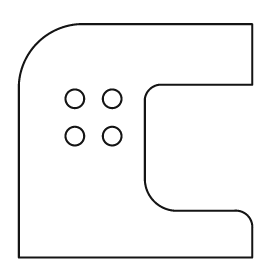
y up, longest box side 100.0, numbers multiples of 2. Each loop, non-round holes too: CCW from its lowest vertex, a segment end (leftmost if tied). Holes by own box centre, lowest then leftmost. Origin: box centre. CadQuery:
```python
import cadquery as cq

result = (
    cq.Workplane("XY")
    .moveTo(-50.0, -50.0)
    .lineTo(50.0, -50.0)
    .lineTo(50.0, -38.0)
    .threePointArc((48.0, -32.0), (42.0, -30.0))
    .lineTo(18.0, -30.0)
    .threePointArc((8.0, -26.0), (4.0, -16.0))
    .lineTo(4.0, 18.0)
    .threePointArc((6.0, 22.0), (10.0, 24.0))
    .lineTo(50.0, 24.0)
    .lineTo(50.0, 50.0)
    .lineTo(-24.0, 50.0)
    .threePointArc((-42.0, 42.0), (-50.0, 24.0))
    .close()
    .moveTo(-26.0, 2.0)
    .circle(4.0)
    .moveTo(-10.0, 2.0)
    .circle(4.0)
    .moveTo(-26.0, 18.0)
    .circle(4.0)
    .moveTo(-10.0, 18.0)
    .circle(4.0)
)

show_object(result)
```